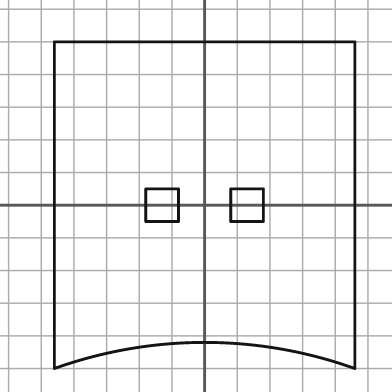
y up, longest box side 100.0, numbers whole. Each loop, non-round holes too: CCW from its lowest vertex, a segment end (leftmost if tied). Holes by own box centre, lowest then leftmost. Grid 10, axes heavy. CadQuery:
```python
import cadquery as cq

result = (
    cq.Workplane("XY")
    .moveTo(-46.0, -50.0)
    .threePointArc((0.0, -42.0), (46.0, -50.0))
    .lineTo(46.0, 50.0)
    .lineTo(-46.0, 50.0)
    .close()
    .moveTo(-18.0, -5.0)
    .lineTo(-8.0, -5.0)
    .lineTo(-8.0, 5.0)
    .lineTo(-18.0, 5.0)
    .close()
    .moveTo(8.0, -5.0)
    .lineTo(18.0, -5.0)
    .lineTo(18.0, 5.0)
    .lineTo(8.0, 5.0)
    .close()
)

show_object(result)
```